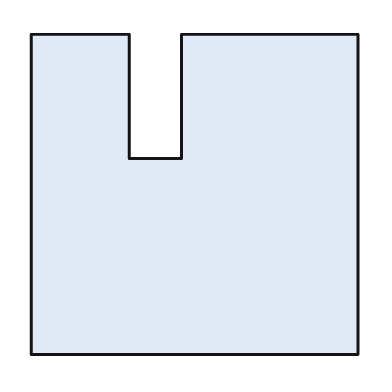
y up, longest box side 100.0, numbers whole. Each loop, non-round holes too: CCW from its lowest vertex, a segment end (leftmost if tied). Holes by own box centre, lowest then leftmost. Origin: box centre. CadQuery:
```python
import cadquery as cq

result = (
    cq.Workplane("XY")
    .moveTo(-50.0, -49.0)
    .lineTo(50.0, -49.0)
    .lineTo(50.0, 49.0)
    .lineTo(-4.0, 49.0)
    .lineTo(-4.0, 11.0)
    .lineTo(-20.0, 11.0)
    .lineTo(-20.0, 49.0)
    .lineTo(-50.0, 49.0)
    .close()
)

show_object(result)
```